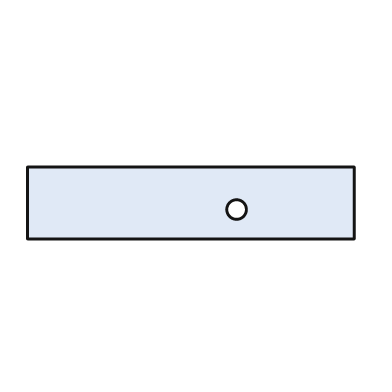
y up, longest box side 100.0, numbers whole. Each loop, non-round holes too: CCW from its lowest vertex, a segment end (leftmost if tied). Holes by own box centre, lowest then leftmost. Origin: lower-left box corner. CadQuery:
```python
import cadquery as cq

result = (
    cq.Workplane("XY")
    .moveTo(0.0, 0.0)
    .lineTo(100.0, 0.0)
    .lineTo(100.0, 22.0)
    .lineTo(0.0, 22.0)
    .close()
    .moveTo(64.0, 9.0)
    .circle(3.0)
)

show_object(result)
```